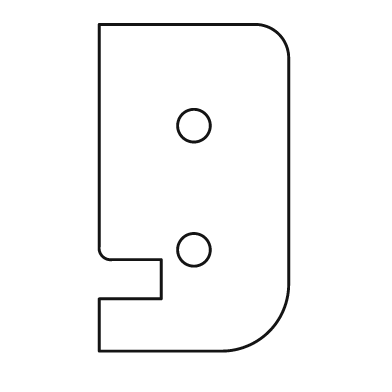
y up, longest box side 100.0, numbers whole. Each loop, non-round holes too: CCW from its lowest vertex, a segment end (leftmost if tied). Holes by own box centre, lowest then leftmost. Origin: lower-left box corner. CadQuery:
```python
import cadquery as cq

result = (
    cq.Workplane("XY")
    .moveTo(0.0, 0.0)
    .lineTo(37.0, 0.0)
    .threePointArc((52.0, 6.0), (58.0, 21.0))
    .lineTo(58.0, 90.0)
    .threePointArc((55.0, 97.0), (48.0, 100.0))
    .lineTo(0.0, 100.0)
    .lineTo(0.0, 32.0)
    .threePointArc((1.0, 29.0), (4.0, 28.0))
    .lineTo(19.0, 28.0)
    .lineTo(19.0, 16.0)
    .lineTo(0.0, 16.0)
    .close()
    .moveTo(29.0, 31.0)
    .circle(5.0)
    .moveTo(29.0, 69.0)
    .circle(5.0)
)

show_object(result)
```